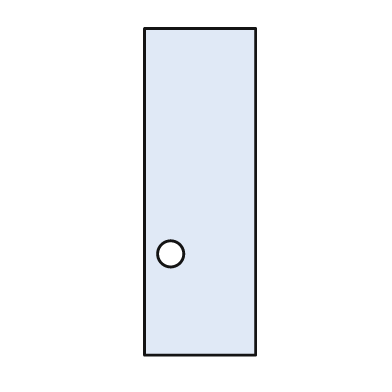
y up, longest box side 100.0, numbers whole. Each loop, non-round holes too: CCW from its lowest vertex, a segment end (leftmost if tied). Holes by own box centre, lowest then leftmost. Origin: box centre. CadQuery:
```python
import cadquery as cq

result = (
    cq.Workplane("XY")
    .moveTo(-17.0, -50.0)
    .lineTo(17.0, -50.0)
    .lineTo(17.0, 50.0)
    .lineTo(-17.0, 50.0)
    .close()
    .moveTo(-9.0, -19.0)
    .circle(4.0)
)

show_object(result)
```